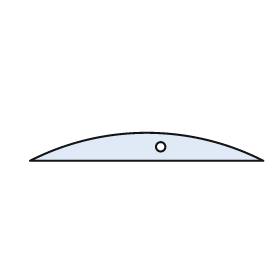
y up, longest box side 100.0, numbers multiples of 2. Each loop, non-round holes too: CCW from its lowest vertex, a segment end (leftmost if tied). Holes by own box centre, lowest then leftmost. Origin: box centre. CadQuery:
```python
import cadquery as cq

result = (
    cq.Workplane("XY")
    .moveTo(-50.0, -6.0)
    .lineTo(50.0, -6.0)
    .threePointArc((0.0, 6.0), (-50.0, -6.0))
    .close()
    .moveTo(6.0, 0.0)
    .circle(2.0)
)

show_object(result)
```